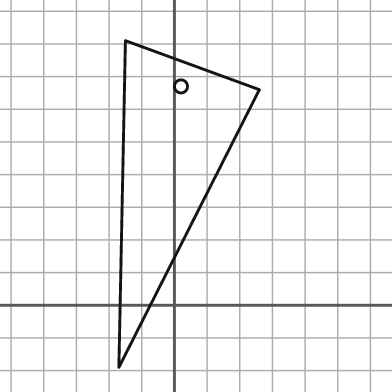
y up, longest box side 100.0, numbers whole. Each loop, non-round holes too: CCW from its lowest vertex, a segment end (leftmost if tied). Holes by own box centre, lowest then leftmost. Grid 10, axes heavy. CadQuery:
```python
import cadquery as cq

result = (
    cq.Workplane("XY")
    .moveTo(-17.0, -19.0)
    .lineTo(26.0, 66.0)
    .lineTo(-15.0, 81.0)
    .close()
    .moveTo(2.0, 67.0)
    .circle(2.0)
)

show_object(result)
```